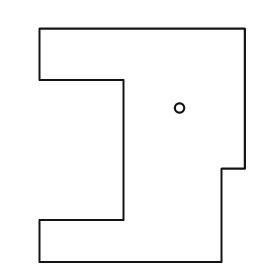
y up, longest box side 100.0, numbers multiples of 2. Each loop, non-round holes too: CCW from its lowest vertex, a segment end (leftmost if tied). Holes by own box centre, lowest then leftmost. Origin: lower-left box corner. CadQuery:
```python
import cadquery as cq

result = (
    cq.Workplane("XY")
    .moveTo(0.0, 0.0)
    .lineTo(78.0, 0.0)
    .lineTo(78.0, 40.0)
    .lineTo(88.0, 40.0)
    .lineTo(88.0, 100.0)
    .lineTo(0.0, 100.0)
    .lineTo(0.0, 78.0)
    .lineTo(36.0, 78.0)
    .lineTo(36.0, 18.0)
    .lineTo(0.0, 18.0)
    .close()
    .moveTo(60.0, 66.0)
    .circle(2.0)
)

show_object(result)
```